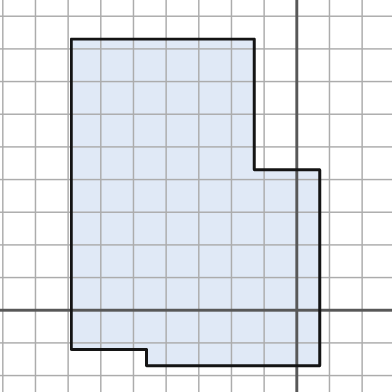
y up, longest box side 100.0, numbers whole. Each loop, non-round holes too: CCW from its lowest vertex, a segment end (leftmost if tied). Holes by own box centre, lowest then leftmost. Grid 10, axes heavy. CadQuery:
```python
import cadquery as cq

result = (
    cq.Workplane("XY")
    .moveTo(-46.0, -17.0)
    .lineTo(7.0, -17.0)
    .lineTo(7.0, 43.0)
    .lineTo(-13.0, 43.0)
    .lineTo(-13.0, 83.0)
    .lineTo(-69.0, 83.0)
    .lineTo(-69.0, -12.0)
    .lineTo(-46.0, -12.0)
    .close()
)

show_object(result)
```